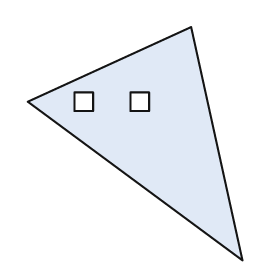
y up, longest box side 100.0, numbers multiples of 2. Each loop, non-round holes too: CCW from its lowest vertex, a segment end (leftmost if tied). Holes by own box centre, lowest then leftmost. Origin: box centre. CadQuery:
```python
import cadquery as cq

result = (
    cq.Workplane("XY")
    .moveTo(46.0, -50.0)
    .lineTo(24.0, 50.0)
    .lineTo(-46.0, 18.0)
    .close()
    .moveTo(-26.0, 14.0)
    .lineTo(-18.0, 14.0)
    .lineTo(-18.0, 22.0)
    .lineTo(-26.0, 22.0)
    .close()
    .moveTo(-2.0, 14.0)
    .lineTo(6.0, 14.0)
    .lineTo(6.0, 22.0)
    .lineTo(-2.0, 22.0)
    .close()
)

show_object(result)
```